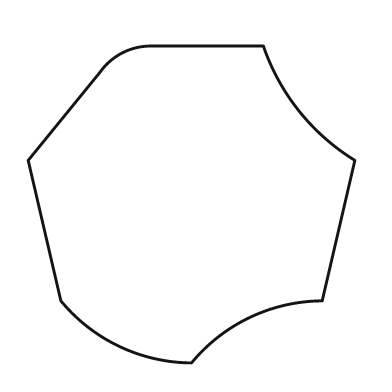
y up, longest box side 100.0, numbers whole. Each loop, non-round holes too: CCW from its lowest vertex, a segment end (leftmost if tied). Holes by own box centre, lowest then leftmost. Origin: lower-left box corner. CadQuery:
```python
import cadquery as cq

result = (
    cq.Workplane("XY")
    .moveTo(50.0, 0.0)
    .threePointArc((68.0, 14.0), (90.0, 19.0))
    .lineTo(100.0, 62.0)
    .threePointArc((83.0, 77.0), (72.0, 97.0))
    .lineTo(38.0, 97.0)
    .threePointArc((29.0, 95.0), (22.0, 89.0))
    .lineTo(0.0, 62.0)
    .lineTo(10.0, 19.0)
    .threePointArc((28.0, 5.0), (50.0, 0.0))
    .close()
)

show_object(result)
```